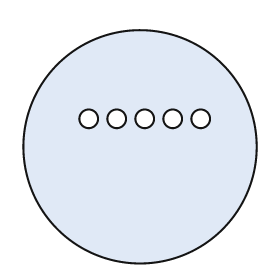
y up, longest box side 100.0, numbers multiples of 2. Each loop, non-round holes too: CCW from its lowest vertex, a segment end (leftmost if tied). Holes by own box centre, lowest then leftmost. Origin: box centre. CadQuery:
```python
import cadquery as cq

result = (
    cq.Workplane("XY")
    .moveTo(0.0, 0.0)
    .circle(50.0)
    .moveTo(-22.0, 12.0)
    .circle(4.0)
    .moveTo(-10.0, 12.0)
    .circle(4.0)
    .moveTo(2.0, 12.0)
    .circle(4.0)
    .moveTo(14.0, 12.0)
    .circle(4.0)
    .moveTo(26.0, 12.0)
    .circle(4.0)
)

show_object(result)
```